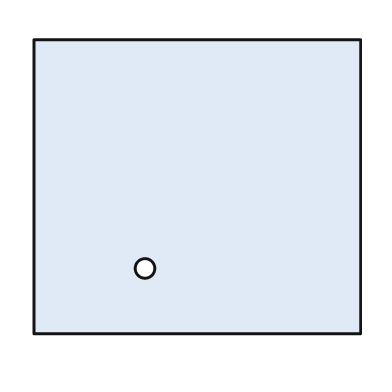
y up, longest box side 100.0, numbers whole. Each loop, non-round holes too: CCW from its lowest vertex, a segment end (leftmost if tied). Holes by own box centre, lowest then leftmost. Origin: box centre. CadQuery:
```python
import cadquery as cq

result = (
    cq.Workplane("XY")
    .moveTo(-50.0, -45.0)
    .lineTo(50.0, -45.0)
    .lineTo(50.0, 45.0)
    .lineTo(-50.0, 45.0)
    .close()
    .moveTo(-16.0, -25.0)
    .circle(3.0)
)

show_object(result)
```